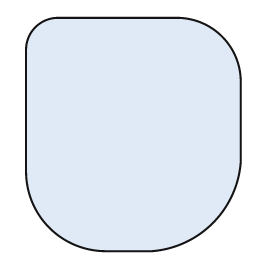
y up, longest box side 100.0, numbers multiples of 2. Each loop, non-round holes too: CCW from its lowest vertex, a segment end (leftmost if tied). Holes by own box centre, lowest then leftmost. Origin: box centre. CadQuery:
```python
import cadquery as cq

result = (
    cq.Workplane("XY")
    .moveTo(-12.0, -50.0)
    .lineTo(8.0, -50.0)
    .threePointArc((34.0, -38.0), (46.0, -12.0))
    .lineTo(46.0, 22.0)
    .threePointArc((38.0, 42.0), (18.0, 50.0))
    .lineTo(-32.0, 50.0)
    .threePointArc((-42.0, 46.0), (-46.0, 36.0))
    .lineTo(-46.0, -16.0)
    .threePointArc((-36.0, -40.0), (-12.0, -50.0))
    .close()
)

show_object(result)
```